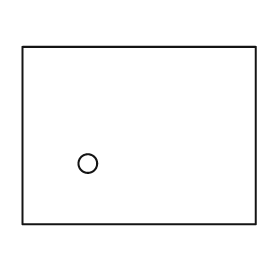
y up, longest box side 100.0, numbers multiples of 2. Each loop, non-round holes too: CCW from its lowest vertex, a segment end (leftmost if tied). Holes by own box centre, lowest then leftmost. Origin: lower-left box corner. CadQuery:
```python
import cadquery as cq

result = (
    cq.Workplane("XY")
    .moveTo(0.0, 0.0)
    .lineTo(100.0, 0.0)
    .lineTo(100.0, 76.0)
    .lineTo(0.0, 76.0)
    .close()
    .moveTo(28.0, 26.0)
    .circle(4.0)
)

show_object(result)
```